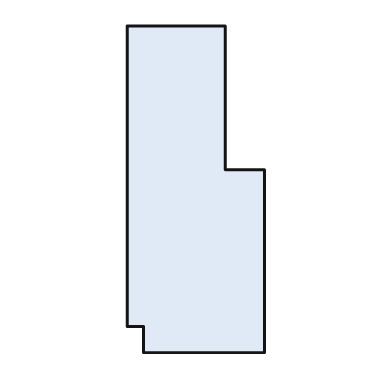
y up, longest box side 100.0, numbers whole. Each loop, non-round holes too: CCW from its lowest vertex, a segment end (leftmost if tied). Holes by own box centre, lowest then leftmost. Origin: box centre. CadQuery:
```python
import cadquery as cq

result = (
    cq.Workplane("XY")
    .moveTo(-16.0, -50.0)
    .lineTo(21.0, -50.0)
    .lineTo(21.0, 6.0)
    .lineTo(9.0, 6.0)
    .lineTo(9.0, 50.0)
    .lineTo(-21.0, 50.0)
    .lineTo(-21.0, -42.0)
    .lineTo(-16.0, -42.0)
    .close()
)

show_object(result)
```